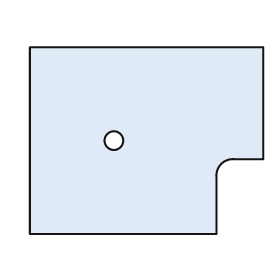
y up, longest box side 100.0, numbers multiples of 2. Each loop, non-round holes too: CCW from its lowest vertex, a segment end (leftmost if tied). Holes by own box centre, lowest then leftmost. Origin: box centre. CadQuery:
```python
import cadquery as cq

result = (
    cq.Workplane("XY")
    .moveTo(-50.0, -40.0)
    .lineTo(30.0, -40.0)
    .lineTo(30.0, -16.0)
    .threePointArc((32.0, -10.0), (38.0, -8.0))
    .lineTo(50.0, -8.0)
    .lineTo(50.0, 40.0)
    .lineTo(-50.0, 40.0)
    .close()
    .moveTo(-14.0, 0.0)
    .circle(4.0)
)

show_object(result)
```